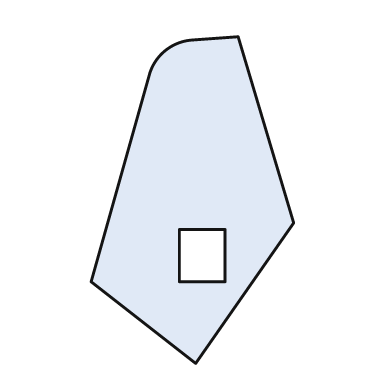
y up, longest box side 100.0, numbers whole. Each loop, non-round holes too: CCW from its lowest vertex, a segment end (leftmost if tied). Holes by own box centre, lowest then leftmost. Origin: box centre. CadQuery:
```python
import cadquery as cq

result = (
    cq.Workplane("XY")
    .moveTo(1.0, -50.0)
    .lineTo(31.0, -7.0)
    .lineTo(14.0, 50.0)
    .lineTo(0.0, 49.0)
    .threePointArc((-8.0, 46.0), (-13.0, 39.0))
    .lineTo(-31.0, -25.0)
    .close()
    .moveTo(-4.0, -25.0)
    .lineTo(10.0, -25.0)
    .lineTo(10.0, -9.0)
    .lineTo(-4.0, -9.0)
    .close()
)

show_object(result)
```